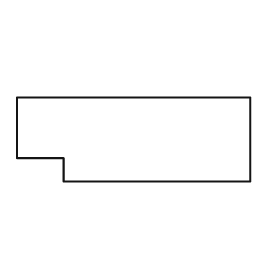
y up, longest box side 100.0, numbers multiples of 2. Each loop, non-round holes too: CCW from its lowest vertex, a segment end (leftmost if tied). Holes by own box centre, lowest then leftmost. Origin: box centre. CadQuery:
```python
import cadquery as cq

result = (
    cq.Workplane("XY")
    .moveTo(-30.0, -18.0)
    .lineTo(50.0, -18.0)
    .lineTo(50.0, 18.0)
    .lineTo(-50.0, 18.0)
    .lineTo(-50.0, -8.0)
    .lineTo(-30.0, -8.0)
    .close()
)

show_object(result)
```